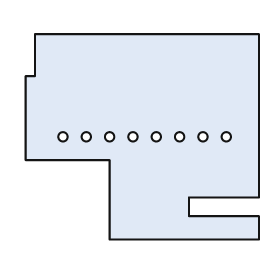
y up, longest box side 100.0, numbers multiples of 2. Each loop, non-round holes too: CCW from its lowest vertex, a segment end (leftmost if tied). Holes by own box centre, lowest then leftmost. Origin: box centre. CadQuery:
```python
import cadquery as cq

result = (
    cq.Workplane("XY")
    .moveTo(-14.0, -44.0)
    .lineTo(50.0, -44.0)
    .lineTo(50.0, -34.0)
    .lineTo(20.0, -34.0)
    .lineTo(20.0, -26.0)
    .lineTo(50.0, -26.0)
    .lineTo(50.0, 44.0)
    .lineTo(-46.0, 44.0)
    .lineTo(-46.0, 26.0)
    .lineTo(-50.0, 26.0)
    .lineTo(-50.0, -10.0)
    .lineTo(-14.0, -10.0)
    .close()
    .moveTo(-34.0, 0.0)
    .circle(2.0)
    .moveTo(-24.0, 0.0)
    .circle(2.0)
    .moveTo(-14.0, 0.0)
    .circle(2.0)
    .moveTo(-4.0, 0.0)
    .circle(2.0)
    .moveTo(6.0, 0.0)
    .circle(2.0)
    .moveTo(16.0, 0.0)
    .circle(2.0)
    .moveTo(26.0, 0.0)
    .circle(2.0)
    .moveTo(36.0, 0.0)
    .circle(2.0)
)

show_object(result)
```